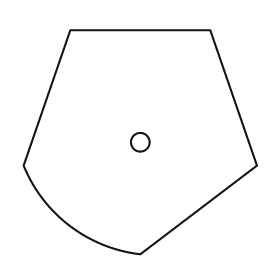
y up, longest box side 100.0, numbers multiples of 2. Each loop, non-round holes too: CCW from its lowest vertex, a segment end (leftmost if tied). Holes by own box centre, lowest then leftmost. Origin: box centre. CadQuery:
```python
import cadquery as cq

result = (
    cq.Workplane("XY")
    .moveTo(0.0, -48.0)
    .lineTo(50.0, -10.0)
    .lineTo(30.0, 48.0)
    .lineTo(-30.0, 48.0)
    .lineTo(-50.0, -10.0)
    .threePointArc((-30.0, -36.0), (0.0, -48.0))
    .close()
    .moveTo(0.0, 0.0)
    .circle(4.0)
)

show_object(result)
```